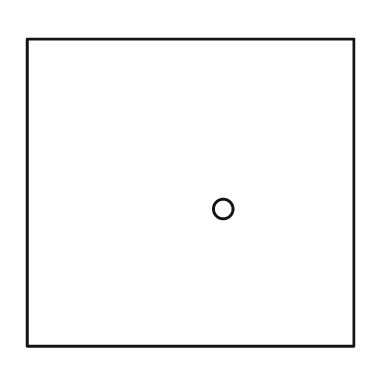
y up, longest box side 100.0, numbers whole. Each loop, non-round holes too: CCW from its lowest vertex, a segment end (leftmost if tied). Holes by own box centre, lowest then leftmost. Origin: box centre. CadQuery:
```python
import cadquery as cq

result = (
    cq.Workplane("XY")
    .moveTo(-50.0, -47.0)
    .lineTo(50.0, -47.0)
    .lineTo(50.0, 47.0)
    .lineTo(-50.0, 47.0)
    .close()
    .moveTo(10.0, -5.0)
    .circle(3.0)
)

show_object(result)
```